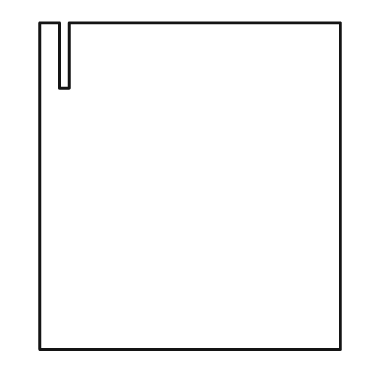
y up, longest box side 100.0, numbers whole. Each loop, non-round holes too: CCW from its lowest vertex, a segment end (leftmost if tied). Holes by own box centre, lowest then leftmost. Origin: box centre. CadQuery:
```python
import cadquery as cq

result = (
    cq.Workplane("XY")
    .moveTo(-46.0, -50.0)
    .lineTo(46.0, -50.0)
    .lineTo(46.0, 50.0)
    .lineTo(-37.0, 50.0)
    .lineTo(-37.0, 30.0)
    .lineTo(-40.0, 30.0)
    .lineTo(-40.0, 50.0)
    .lineTo(-46.0, 50.0)
    .close()
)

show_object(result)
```